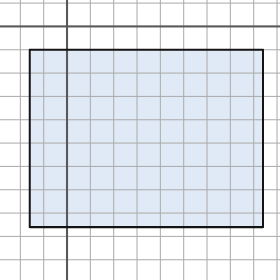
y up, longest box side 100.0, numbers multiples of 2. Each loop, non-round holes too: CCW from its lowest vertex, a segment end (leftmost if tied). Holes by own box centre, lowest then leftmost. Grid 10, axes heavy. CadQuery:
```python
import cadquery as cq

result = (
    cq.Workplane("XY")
    .moveTo(-16.0, -86.0)
    .lineTo(84.0, -86.0)
    .lineTo(84.0, -10.0)
    .lineTo(-16.0, -10.0)
    .close()
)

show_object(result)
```